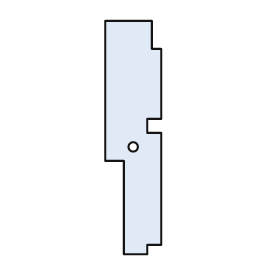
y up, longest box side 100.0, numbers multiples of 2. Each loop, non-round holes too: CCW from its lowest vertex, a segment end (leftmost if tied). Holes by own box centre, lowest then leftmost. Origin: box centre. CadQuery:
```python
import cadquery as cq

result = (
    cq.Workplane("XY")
    .moveTo(-4.0, -50.0)
    .lineTo(6.0, -50.0)
    .lineTo(6.0, -46.0)
    .lineTo(12.0, -46.0)
    .lineTo(12.0, 2.0)
    .lineTo(6.0, 2.0)
    .lineTo(6.0, 8.0)
    .lineTo(12.0, 8.0)
    .lineTo(12.0, 38.0)
    .lineTo(8.0, 38.0)
    .lineTo(8.0, 50.0)
    .lineTo(-12.0, 50.0)
    .lineTo(-12.0, -10.0)
    .lineTo(-4.0, -10.0)
    .close()
    .moveTo(0.0, -4.0)
    .circle(2.0)
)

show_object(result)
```